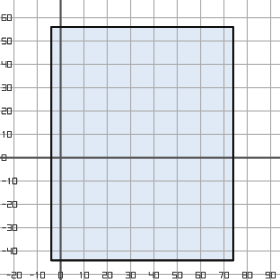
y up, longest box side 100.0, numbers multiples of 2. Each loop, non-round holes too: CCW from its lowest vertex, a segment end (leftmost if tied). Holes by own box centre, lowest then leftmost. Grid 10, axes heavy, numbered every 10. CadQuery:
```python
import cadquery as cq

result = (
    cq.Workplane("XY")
    .moveTo(-4.0, -44.0)
    .lineTo(74.0, -44.0)
    .lineTo(74.0, 56.0)
    .lineTo(-4.0, 56.0)
    .close()
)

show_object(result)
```